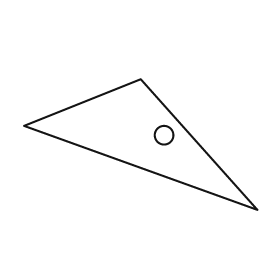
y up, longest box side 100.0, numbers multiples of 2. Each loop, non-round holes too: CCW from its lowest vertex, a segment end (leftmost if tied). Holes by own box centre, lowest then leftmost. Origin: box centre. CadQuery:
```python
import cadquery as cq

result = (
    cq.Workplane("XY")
    .moveTo(50.0, -28.0)
    .lineTo(0.0, 28.0)
    .lineTo(-50.0, 8.0)
    .close()
    .moveTo(10.0, 4.0)
    .circle(4.0)
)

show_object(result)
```